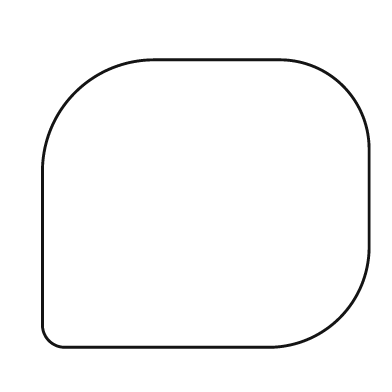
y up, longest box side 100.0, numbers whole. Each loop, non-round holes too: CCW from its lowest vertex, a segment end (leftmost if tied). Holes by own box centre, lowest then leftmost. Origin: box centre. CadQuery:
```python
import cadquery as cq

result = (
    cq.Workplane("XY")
    .moveTo(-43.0, -44.0)
    .lineTo(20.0, -44.0)
    .threePointArc((41.0, -35.0), (50.0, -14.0))
    .lineTo(50.0, 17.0)
    .threePointArc((42.0, 36.0), (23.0, 44.0))
    .lineTo(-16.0, 44.0)
    .threePointArc((-40.0, 34.0), (-50.0, 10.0))
    .lineTo(-50.0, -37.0)
    .threePointArc((-48.0, -42.0), (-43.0, -44.0))
    .close()
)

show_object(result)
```